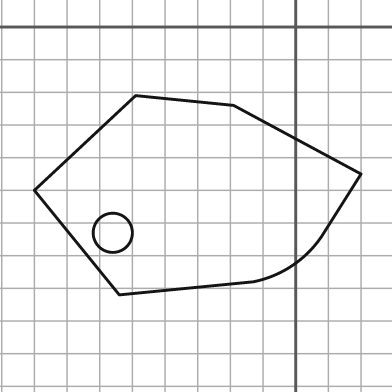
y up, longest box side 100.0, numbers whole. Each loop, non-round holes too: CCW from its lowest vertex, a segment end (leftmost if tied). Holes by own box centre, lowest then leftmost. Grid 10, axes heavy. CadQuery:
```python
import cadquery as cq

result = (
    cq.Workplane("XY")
    .moveTo(-54.0, -82.0)
    .lineTo(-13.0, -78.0)
    .threePointArc((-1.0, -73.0), (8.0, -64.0))
    .lineTo(20.0, -45.0)
    .lineTo(-19.0, -24.0)
    .lineTo(-49.0, -21.0)
    .lineTo(-80.0, -50.0)
    .close()
    .moveTo(-56.0, -63.0)
    .circle(6.0)
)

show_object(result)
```